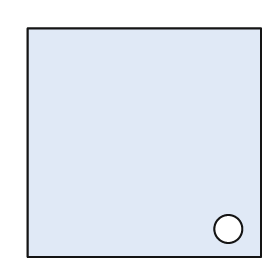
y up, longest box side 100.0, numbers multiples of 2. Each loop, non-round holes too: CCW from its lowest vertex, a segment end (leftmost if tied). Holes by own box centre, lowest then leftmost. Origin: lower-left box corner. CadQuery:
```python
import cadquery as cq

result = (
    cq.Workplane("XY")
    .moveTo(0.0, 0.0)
    .lineTo(100.0, 0.0)
    .lineTo(100.0, 98.0)
    .lineTo(0.0, 98.0)
    .close()
    .moveTo(86.0, 12.0)
    .circle(6.0)
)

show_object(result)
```